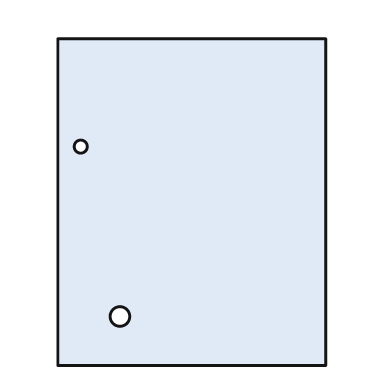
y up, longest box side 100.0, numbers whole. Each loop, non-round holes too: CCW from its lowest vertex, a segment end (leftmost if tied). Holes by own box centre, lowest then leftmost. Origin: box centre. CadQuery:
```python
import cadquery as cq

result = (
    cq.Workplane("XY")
    .moveTo(-41.0, -50.0)
    .lineTo(41.0, -50.0)
    .lineTo(41.0, 50.0)
    .lineTo(-41.0, 50.0)
    .close()
    .moveTo(-22.0, -35.0)
    .circle(3.0)
    .moveTo(-34.0, 17.0)
    .circle(2.0)
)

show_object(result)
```